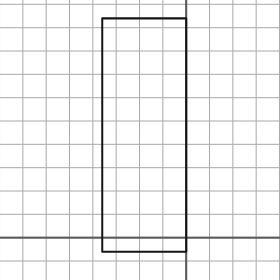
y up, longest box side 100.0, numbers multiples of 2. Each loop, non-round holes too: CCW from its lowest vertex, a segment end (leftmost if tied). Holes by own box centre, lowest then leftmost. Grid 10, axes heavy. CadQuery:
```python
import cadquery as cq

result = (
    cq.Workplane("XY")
    .moveTo(-36.0, -6.0)
    .lineTo(0.0, -6.0)
    .lineTo(0.0, 94.0)
    .lineTo(-36.0, 94.0)
    .close()
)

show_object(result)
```